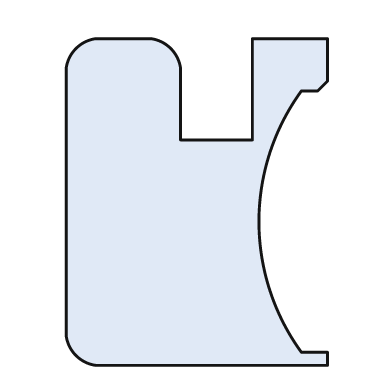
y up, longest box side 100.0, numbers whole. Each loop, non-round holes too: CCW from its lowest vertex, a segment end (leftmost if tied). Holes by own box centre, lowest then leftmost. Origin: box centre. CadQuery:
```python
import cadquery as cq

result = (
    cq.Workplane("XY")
    .moveTo(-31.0, -50.0)
    .lineTo(40.0, -50.0)
    .lineTo(40.0, -46.0)
    .lineTo(32.0, -46.0)
    .threePointArc((19.0, -6.0), (32.0, 34.0))
    .lineTo(37.0, 34.0)
    .lineTo(40.0, 37.0)
    .lineTo(40.0, 50.0)
    .lineTo(17.0, 50.0)
    .lineTo(17.0, 19.0)
    .lineTo(-5.0, 19.0)
    .lineTo(-5.0, 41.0)
    .threePointArc((-8.0, 47.0), (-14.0, 50.0))
    .lineTo(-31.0, 50.0)
    .threePointArc((-37.0, 47.0), (-40.0, 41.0))
    .lineTo(-40.0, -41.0)
    .threePointArc((-37.0, -47.0), (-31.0, -50.0))
    .close()
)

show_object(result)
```